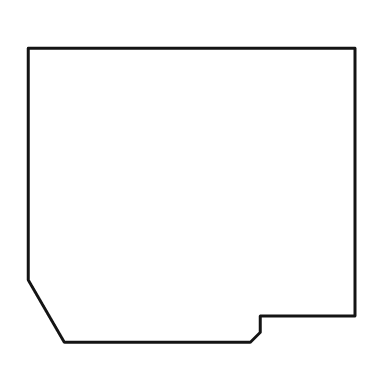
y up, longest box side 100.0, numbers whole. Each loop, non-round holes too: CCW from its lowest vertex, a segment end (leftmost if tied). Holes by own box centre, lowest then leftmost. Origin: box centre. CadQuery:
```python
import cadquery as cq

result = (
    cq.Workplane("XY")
    .moveTo(-39.0, -45.0)
    .lineTo(18.0, -45.0)
    .lineTo(21.0, -42.0)
    .lineTo(21.0, -37.0)
    .lineTo(50.0, -37.0)
    .lineTo(50.0, 45.0)
    .lineTo(-50.0, 45.0)
    .lineTo(-50.0, -26.0)
    .close()
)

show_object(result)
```